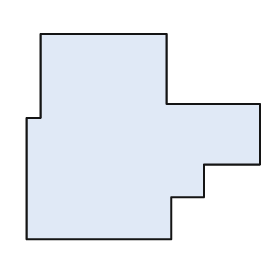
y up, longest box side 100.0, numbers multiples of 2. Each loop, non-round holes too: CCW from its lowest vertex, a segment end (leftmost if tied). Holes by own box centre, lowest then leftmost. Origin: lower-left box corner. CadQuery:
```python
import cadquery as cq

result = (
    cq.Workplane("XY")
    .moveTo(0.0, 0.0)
    .lineTo(62.0, 0.0)
    .lineTo(62.0, 18.0)
    .lineTo(76.0, 18.0)
    .lineTo(76.0, 32.0)
    .lineTo(100.0, 32.0)
    .lineTo(100.0, 58.0)
    .lineTo(60.0, 58.0)
    .lineTo(60.0, 88.0)
    .lineTo(6.0, 88.0)
    .lineTo(6.0, 52.0)
    .lineTo(0.0, 52.0)
    .close()
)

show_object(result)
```